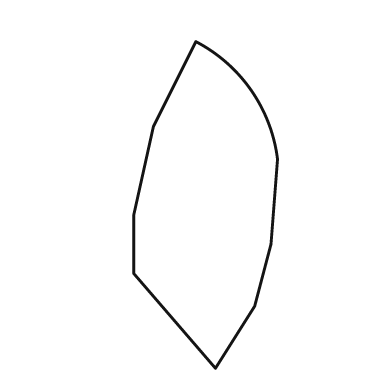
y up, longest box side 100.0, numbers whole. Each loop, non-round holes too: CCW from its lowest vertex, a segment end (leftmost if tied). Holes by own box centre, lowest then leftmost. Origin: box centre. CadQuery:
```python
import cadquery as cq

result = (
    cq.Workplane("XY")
    .moveTo(3.0, -50.0)
    .lineTo(15.0, -31.0)
    .lineTo(20.0, -12.0)
    .lineTo(22.0, 14.0)
    .threePointArc((14.0, 35.0), (-3.0, 50.0))
    .lineTo(-16.0, 24.0)
    .lineTo(-22.0, -3.0)
    .lineTo(-22.0, -21.0)
    .close()
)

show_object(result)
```